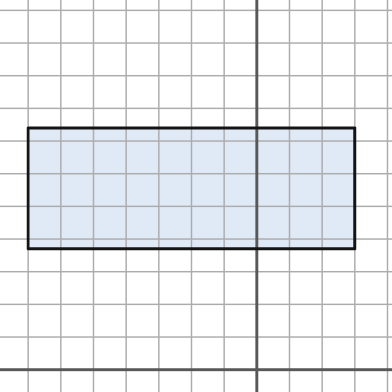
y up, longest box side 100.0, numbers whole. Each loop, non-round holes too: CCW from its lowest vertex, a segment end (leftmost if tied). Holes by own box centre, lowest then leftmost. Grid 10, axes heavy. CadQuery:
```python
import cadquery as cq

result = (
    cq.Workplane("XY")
    .moveTo(-70.0, 37.0)
    .lineTo(30.0, 37.0)
    .lineTo(30.0, 74.0)
    .lineTo(-70.0, 74.0)
    .close()
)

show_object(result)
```